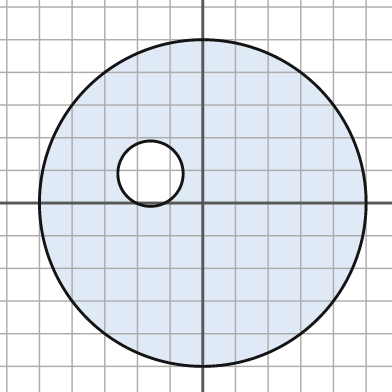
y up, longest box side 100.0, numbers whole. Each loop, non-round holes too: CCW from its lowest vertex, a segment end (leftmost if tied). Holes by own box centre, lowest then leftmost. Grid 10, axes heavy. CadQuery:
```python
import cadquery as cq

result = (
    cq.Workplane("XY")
    .moveTo(0.0, 0.0)
    .circle(50.0)
    .moveTo(-16.0, 9.0)
    .circle(10.0)
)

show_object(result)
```